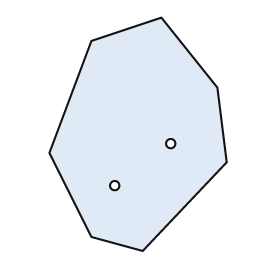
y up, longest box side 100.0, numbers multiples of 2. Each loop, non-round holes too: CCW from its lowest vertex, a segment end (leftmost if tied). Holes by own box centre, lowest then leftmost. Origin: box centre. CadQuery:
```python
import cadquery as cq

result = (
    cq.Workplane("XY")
    .moveTo(2.0, -50.0)
    .lineTo(38.0, -12.0)
    .lineTo(34.0, 20.0)
    .lineTo(10.0, 50.0)
    .lineTo(-20.0, 40.0)
    .lineTo(-38.0, -8.0)
    .lineTo(-20.0, -44.0)
    .close()
    .moveTo(-10.0, -22.0)
    .circle(2.0)
    .moveTo(14.0, -4.0)
    .circle(2.0)
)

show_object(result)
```